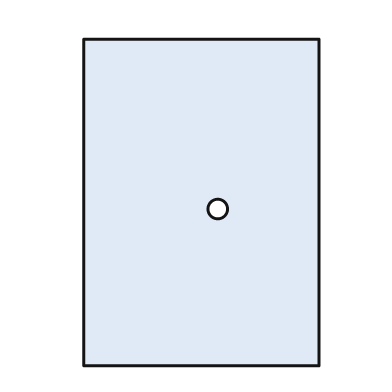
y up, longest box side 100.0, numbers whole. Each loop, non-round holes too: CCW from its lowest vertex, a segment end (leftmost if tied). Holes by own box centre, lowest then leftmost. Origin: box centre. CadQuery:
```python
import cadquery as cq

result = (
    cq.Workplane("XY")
    .moveTo(-36.0, -50.0)
    .lineTo(36.0, -50.0)
    .lineTo(36.0, 50.0)
    .lineTo(-36.0, 50.0)
    .close()
    .moveTo(5.0, -2.0)
    .circle(3.0)
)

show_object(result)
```